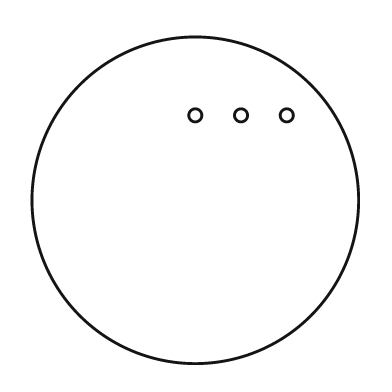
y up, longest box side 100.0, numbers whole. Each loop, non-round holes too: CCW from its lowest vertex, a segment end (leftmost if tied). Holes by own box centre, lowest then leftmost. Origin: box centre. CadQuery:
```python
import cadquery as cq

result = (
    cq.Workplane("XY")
    .moveTo(0.0, 0.0)
    .circle(50.0)
    .moveTo(0.0, 26.0)
    .circle(2.0)
    .moveTo(14.0, 26.0)
    .circle(2.0)
    .moveTo(28.0, 26.0)
    .circle(2.0)
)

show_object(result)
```